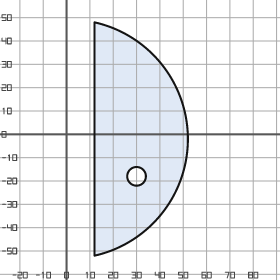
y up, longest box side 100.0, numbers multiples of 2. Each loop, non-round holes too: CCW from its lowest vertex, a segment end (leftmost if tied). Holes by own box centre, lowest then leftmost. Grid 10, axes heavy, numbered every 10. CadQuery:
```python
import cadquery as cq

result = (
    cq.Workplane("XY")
    .moveTo(12.0, -52.0)
    .threePointArc((52.0, -2.0), (12.0, 48.0))
    .close()
    .moveTo(30.0, -18.0)
    .circle(4.0)
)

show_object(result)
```